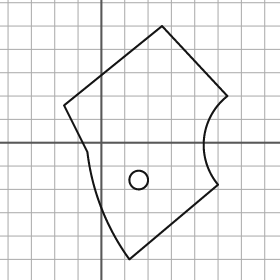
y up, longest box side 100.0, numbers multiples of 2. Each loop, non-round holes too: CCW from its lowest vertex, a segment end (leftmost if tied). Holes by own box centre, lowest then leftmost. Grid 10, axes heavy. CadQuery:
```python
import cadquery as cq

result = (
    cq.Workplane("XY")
    .moveTo(12.0, -50.0)
    .lineTo(50.0, -18.0)
    .threePointArc((44.0, 2.0), (54.0, 20.0))
    .lineTo(26.0, 50.0)
    .lineTo(-16.0, 16.0)
    .lineTo(-6.0, -4.0)
    .threePointArc((0.0, -28.0), (12.0, -50.0))
    .close()
    .moveTo(16.0, -16.0)
    .circle(4.0)
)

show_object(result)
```